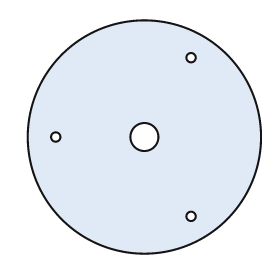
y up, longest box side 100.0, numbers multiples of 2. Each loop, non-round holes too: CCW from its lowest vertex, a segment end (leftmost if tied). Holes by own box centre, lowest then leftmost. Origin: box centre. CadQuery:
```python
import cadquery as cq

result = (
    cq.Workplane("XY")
    .moveTo(0.0, 0.0)
    .circle(50.0)
    .moveTo(20.0, -34.0)
    .circle(2.0)
    .moveTo(-38.0, 0.0)
    .circle(2.0)
    .moveTo(0.0, 0.0)
    .circle(6.0)
    .moveTo(20.0, 34.0)
    .circle(2.0)
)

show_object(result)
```